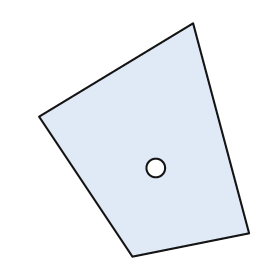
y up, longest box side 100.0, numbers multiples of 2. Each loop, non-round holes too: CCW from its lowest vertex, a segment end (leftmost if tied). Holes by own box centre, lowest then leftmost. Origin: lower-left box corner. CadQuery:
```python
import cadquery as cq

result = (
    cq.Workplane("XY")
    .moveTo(40.0, 0.0)
    .lineTo(90.0, 10.0)
    .lineTo(66.0, 100.0)
    .lineTo(0.0, 60.0)
    .close()
    .moveTo(50.0, 38.0)
    .circle(4.0)
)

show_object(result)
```